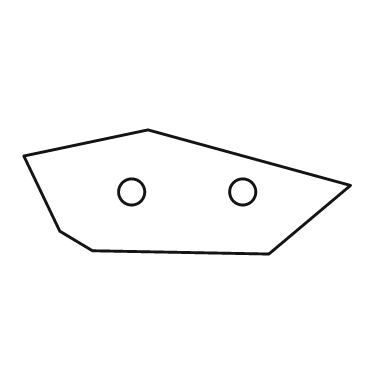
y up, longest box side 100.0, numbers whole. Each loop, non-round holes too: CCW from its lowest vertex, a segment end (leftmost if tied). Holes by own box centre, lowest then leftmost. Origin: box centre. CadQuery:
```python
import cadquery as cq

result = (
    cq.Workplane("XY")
    .moveTo(25.0, -19.0)
    .lineTo(50.0, 2.0)
    .lineTo(-12.0, 19.0)
    .lineTo(-50.0, 11.0)
    .lineTo(-39.0, -12.0)
    .lineTo(-29.0, -18.0)
    .close()
    .moveTo(-17.0, 0.0)
    .circle(4.0)
    .moveTo(17.0, 0.0)
    .circle(4.0)
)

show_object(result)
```